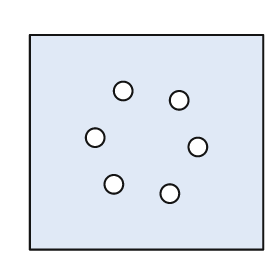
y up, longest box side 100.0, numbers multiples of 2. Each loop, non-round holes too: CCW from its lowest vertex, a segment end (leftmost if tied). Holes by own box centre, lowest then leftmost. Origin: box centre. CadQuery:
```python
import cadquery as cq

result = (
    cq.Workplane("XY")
    .moveTo(-50.0, -46.0)
    .lineTo(50.0, -46.0)
    .lineTo(50.0, 46.0)
    .lineTo(-50.0, 46.0)
    .close()
    .moveTo(10.0, -22.0)
    .circle(4.0)
    .moveTo(-14.0, -18.0)
    .circle(4.0)
    .moveTo(22.0, -2.0)
    .circle(4.0)
    .moveTo(-22.0, 2.0)
    .circle(4.0)
    .moveTo(14.0, 18.0)
    .circle(4.0)
    .moveTo(-10.0, 22.0)
    .circle(4.0)
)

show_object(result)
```